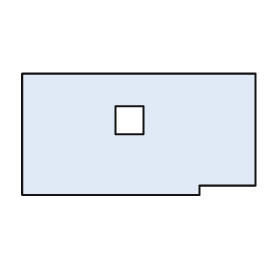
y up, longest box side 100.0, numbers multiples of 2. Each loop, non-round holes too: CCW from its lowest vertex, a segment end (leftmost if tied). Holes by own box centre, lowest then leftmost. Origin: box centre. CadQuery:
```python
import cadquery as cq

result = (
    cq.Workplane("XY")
    .moveTo(-50.0, -26.0)
    .lineTo(26.0, -26.0)
    .lineTo(26.0, -22.0)
    .lineTo(50.0, -22.0)
    .lineTo(50.0, 26.0)
    .lineTo(-50.0, 26.0)
    .close()
    .moveTo(-10.0, 0.0)
    .lineTo(2.0, 0.0)
    .lineTo(2.0, 12.0)
    .lineTo(-10.0, 12.0)
    .close()
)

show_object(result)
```